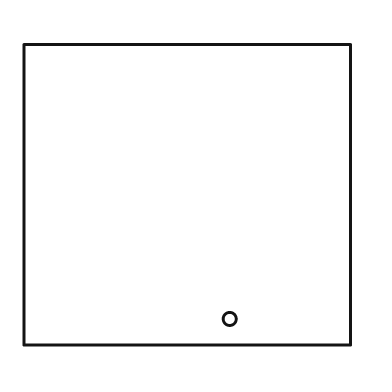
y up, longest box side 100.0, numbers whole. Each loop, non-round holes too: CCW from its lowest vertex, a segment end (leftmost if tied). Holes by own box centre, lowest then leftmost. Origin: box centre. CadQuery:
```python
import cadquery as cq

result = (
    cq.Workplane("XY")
    .moveTo(-50.0, -46.0)
    .lineTo(50.0, -46.0)
    .lineTo(50.0, 46.0)
    .lineTo(-50.0, 46.0)
    .close()
    .moveTo(13.0, -38.0)
    .circle(2.0)
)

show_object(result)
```